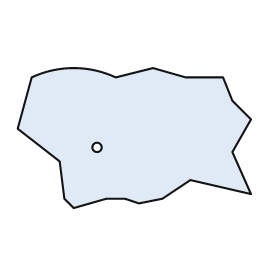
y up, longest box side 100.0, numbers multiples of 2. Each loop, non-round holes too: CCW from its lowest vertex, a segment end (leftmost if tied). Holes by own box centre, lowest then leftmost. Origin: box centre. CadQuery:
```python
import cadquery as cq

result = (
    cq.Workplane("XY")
    .moveTo(-26.0, -30.0)
    .lineTo(-12.0, -26.0)
    .lineTo(-4.0, -26.0)
    .lineTo(2.0, -28.0)
    .lineTo(12.0, -26.0)
    .lineTo(24.0, -18.0)
    .lineTo(50.0, -24.0)
    .lineTo(42.0, -6.0)
    .lineTo(50.0, 8.0)
    .lineTo(42.0, 16.0)
    .lineTo(38.0, 26.0)
    .lineTo(22.0, 26.0)
    .lineTo(8.0, 30.0)
    .lineTo(-8.0, 26.0)
    .threePointArc((-26.0, 30.0), (-44.0, 26.0))
    .lineTo(-50.0, 4.0)
    .lineTo(-32.0, -10.0)
    .lineTo(-30.0, -26.0)
    .close()
    .moveTo(-16.0, -4.0)
    .circle(2.0)
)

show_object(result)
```